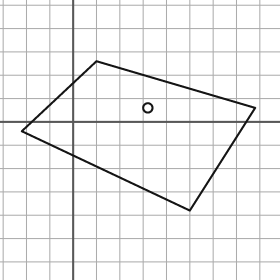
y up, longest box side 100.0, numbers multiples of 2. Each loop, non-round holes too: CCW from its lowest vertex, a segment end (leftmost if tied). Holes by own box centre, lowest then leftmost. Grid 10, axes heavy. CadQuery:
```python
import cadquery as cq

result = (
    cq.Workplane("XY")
    .moveTo(50.0, -38.0)
    .lineTo(78.0, 6.0)
    .lineTo(10.0, 26.0)
    .lineTo(-22.0, -4.0)
    .close()
    .moveTo(32.0, 6.0)
    .circle(2.0)
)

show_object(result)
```